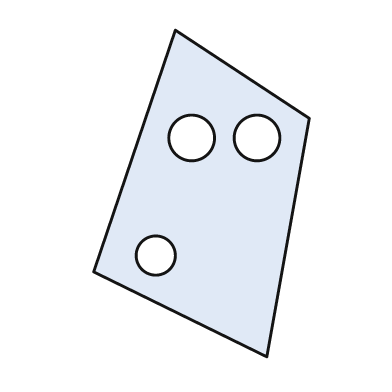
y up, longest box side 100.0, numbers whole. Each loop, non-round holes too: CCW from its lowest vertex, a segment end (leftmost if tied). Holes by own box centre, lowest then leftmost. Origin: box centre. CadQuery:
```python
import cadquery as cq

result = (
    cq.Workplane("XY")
    .moveTo(20.0, -50.0)
    .lineTo(33.0, 23.0)
    .lineTo(-8.0, 50.0)
    .lineTo(-33.0, -24.0)
    .close()
    .moveTo(-14.0, -19.0)
    .circle(6.0)
    .moveTo(-3.0, 17.0)
    .circle(7.0)
    .moveTo(17.0, 17.0)
    .circle(7.0)
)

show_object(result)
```